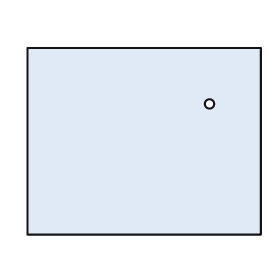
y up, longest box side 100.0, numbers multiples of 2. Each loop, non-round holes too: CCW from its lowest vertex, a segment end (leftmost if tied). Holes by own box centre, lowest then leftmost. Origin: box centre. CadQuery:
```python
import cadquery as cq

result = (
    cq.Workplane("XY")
    .moveTo(-50.0, -40.0)
    .lineTo(50.0, -40.0)
    .lineTo(50.0, 40.0)
    .lineTo(-50.0, 40.0)
    .close()
    .moveTo(28.0, 16.0)
    .circle(2.0)
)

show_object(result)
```